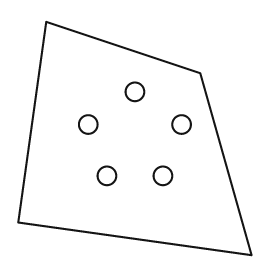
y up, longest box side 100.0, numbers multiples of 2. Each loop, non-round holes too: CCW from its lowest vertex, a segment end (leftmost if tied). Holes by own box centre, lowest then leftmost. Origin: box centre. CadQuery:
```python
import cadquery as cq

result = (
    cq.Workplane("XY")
    .moveTo(50.0, -50.0)
    .lineTo(28.0, 28.0)
    .lineTo(-38.0, 50.0)
    .lineTo(-50.0, -36.0)
    .close()
    .moveTo(-12.0, -16.0)
    .circle(4.0)
    .moveTo(12.0, -16.0)
    .circle(4.0)
    .moveTo(-20.0, 6.0)
    .circle(4.0)
    .moveTo(20.0, 6.0)
    .circle(4.0)
    .moveTo(0.0, 20.0)
    .circle(4.0)
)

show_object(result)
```